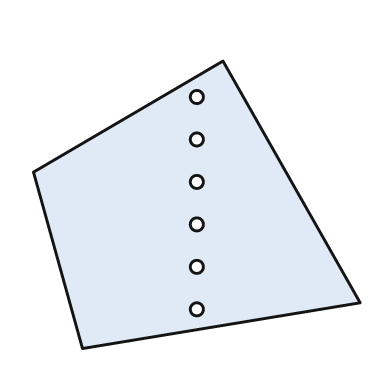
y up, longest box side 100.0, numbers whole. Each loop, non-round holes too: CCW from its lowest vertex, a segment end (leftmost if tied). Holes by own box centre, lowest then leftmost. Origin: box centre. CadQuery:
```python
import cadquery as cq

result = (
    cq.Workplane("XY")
    .moveTo(-35.0, -44.0)
    .lineTo(50.0, -30.0)
    .lineTo(8.0, 44.0)
    .lineTo(-50.0, 10.0)
    .close()
    .moveTo(0.0, -32.0)
    .circle(2.0)
    .moveTo(0.0, -19.0)
    .circle(2.0)
    .moveTo(0.0, -6.0)
    .circle(2.0)
    .moveTo(0.0, 7.0)
    .circle(2.0)
    .moveTo(0.0, 20.0)
    .circle(2.0)
    .moveTo(0.0, 33.0)
    .circle(2.0)
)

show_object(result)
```